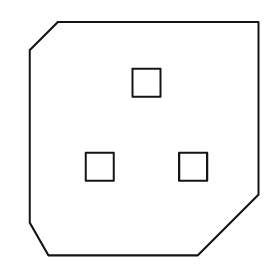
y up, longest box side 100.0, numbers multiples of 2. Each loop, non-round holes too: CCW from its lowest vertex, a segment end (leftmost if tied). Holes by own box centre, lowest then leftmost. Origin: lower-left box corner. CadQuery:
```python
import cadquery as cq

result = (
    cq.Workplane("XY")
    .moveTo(8.0, 0.0)
    .lineTo(72.0, 0.0)
    .lineTo(98.0, 26.0)
    .lineTo(98.0, 100.0)
    .lineTo(12.0, 100.0)
    .lineTo(0.0, 88.0)
    .lineTo(0.0, 14.0)
    .close()
    .moveTo(24.0, 32.0)
    .lineTo(36.0, 32.0)
    .lineTo(36.0, 44.0)
    .lineTo(24.0, 44.0)
    .close()
    .moveTo(64.0, 32.0)
    .lineTo(76.0, 32.0)
    .lineTo(76.0, 44.0)
    .lineTo(64.0, 44.0)
    .close()
    .moveTo(44.0, 68.0)
    .lineTo(56.0, 68.0)
    .lineTo(56.0, 80.0)
    .lineTo(44.0, 80.0)
    .close()
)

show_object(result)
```